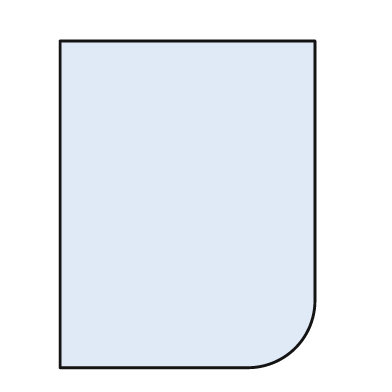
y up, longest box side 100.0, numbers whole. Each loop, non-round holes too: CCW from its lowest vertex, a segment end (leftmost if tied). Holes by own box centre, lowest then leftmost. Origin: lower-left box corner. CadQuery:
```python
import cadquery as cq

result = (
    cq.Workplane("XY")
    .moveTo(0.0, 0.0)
    .lineTo(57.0, 0.0)
    .threePointArc((72.0, 6.0), (78.0, 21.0))
    .lineTo(78.0, 100.0)
    .lineTo(0.0, 100.0)
    .close()
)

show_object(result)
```